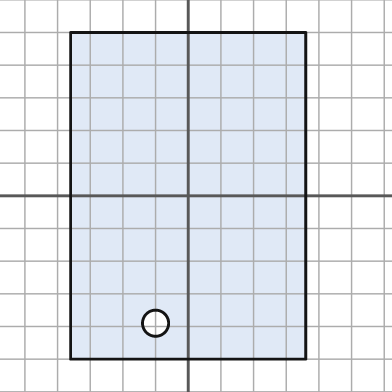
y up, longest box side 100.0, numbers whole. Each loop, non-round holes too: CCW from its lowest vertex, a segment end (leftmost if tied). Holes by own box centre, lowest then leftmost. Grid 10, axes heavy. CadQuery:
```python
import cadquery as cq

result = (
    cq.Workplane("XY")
    .moveTo(-36.0, -50.0)
    .lineTo(36.0, -50.0)
    .lineTo(36.0, 50.0)
    .lineTo(-36.0, 50.0)
    .close()
    .moveTo(-10.0, -39.0)
    .circle(4.0)
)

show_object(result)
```